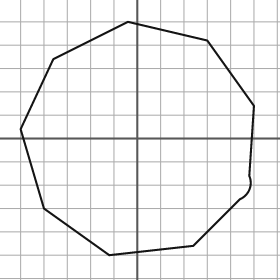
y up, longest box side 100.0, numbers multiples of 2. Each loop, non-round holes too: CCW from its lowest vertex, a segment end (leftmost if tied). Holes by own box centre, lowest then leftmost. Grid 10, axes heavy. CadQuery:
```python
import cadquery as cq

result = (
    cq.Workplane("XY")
    .moveTo(-12.0, -50.0)
    .lineTo(24.0, -46.0)
    .lineTo(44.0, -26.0)
    .threePointArc((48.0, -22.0), (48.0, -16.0))
    .lineTo(50.0, 14.0)
    .lineTo(30.0, 42.0)
    .lineTo(-4.0, 50.0)
    .lineTo(-36.0, 34.0)
    .lineTo(-50.0, 4.0)
    .lineTo(-40.0, -30.0)
    .close()
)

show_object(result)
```